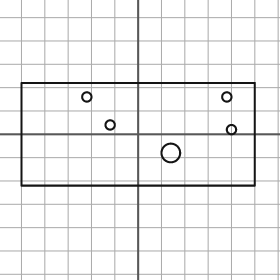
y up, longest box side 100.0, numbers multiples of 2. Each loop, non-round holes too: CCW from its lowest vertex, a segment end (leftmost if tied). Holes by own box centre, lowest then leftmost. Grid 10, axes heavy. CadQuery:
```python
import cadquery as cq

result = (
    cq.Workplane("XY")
    .moveTo(-50.0, -22.0)
    .lineTo(50.0, -22.0)
    .lineTo(50.0, 22.0)
    .lineTo(-50.0, 22.0)
    .close()
    .moveTo(14.0, -8.0)
    .circle(4.0)
    .moveTo(40.0, 2.0)
    .circle(2.0)
    .moveTo(-12.0, 4.0)
    .circle(2.0)
    .moveTo(-22.0, 16.0)
    .circle(2.0)
    .moveTo(38.0, 16.0)
    .circle(2.0)
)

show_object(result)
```